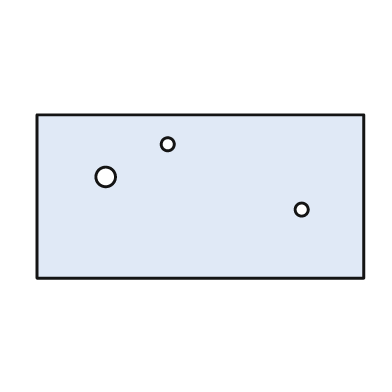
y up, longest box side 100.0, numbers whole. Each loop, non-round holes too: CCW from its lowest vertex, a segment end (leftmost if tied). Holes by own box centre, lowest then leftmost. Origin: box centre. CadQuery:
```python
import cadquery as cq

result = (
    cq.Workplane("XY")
    .moveTo(-50.0, -25.0)
    .lineTo(50.0, -25.0)
    .lineTo(50.0, 25.0)
    .lineTo(-50.0, 25.0)
    .close()
    .moveTo(31.0, -4.0)
    .circle(2.0)
    .moveTo(-29.0, 6.0)
    .circle(3.0)
    .moveTo(-10.0, 16.0)
    .circle(2.0)
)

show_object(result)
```